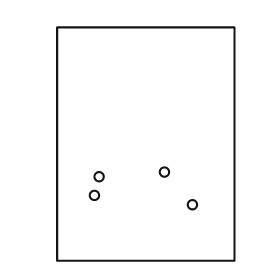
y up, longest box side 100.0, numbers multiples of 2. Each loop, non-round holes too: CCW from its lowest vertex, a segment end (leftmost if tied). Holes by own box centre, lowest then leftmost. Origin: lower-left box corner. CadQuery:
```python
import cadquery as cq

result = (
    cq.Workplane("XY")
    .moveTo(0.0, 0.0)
    .lineTo(76.0, 0.0)
    .lineTo(76.0, 100.0)
    .lineTo(0.0, 100.0)
    .close()
    .moveTo(58.0, 24.0)
    .circle(2.0)
    .moveTo(16.0, 28.0)
    .circle(2.0)
    .moveTo(18.0, 36.0)
    .circle(2.0)
    .moveTo(46.0, 38.0)
    .circle(2.0)
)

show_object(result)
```